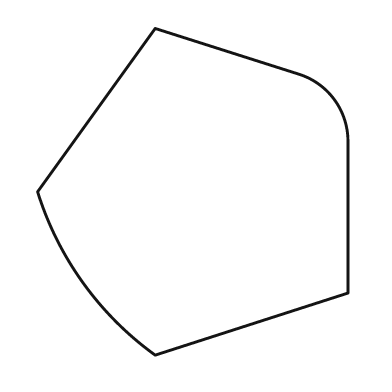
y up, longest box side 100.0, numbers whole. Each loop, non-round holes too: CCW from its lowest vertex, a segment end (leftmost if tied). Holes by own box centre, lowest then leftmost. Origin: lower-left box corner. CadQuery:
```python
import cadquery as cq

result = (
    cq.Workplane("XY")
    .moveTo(36.0, 0.0)
    .lineTo(95.0, 19.0)
    .lineTo(95.0, 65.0)
    .threePointArc((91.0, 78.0), (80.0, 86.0))
    .lineTo(36.0, 100.0)
    .lineTo(0.0, 50.0)
    .threePointArc((14.0, 22.0), (36.0, 0.0))
    .close()
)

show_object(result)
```